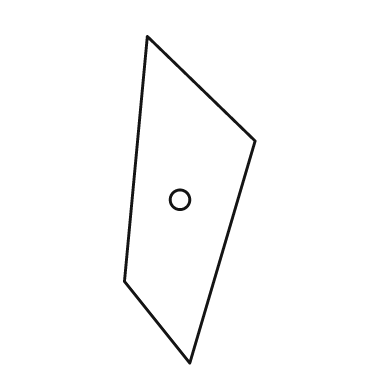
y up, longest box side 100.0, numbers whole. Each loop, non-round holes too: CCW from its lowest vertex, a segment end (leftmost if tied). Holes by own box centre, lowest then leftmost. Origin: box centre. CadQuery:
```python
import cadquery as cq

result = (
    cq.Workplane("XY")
    .moveTo(0.0, -50.0)
    .lineTo(20.0, 18.0)
    .lineTo(-13.0, 50.0)
    .lineTo(-20.0, -25.0)
    .close()
    .moveTo(-3.0, 0.0)
    .circle(3.0)
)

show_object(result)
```